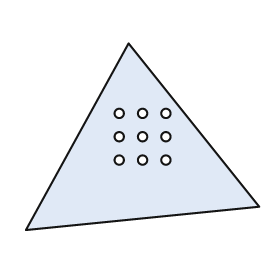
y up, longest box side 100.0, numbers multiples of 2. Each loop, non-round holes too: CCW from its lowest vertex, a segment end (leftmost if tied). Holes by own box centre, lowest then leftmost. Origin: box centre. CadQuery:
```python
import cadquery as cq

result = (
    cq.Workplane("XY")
    .moveTo(-50.0, -40.0)
    .lineTo(50.0, -30.0)
    .lineTo(-6.0, 40.0)
    .close()
    .moveTo(-10.0, -10.0)
    .circle(2.0)
    .moveTo(0.0, -10.0)
    .circle(2.0)
    .moveTo(10.0, -10.0)
    .circle(2.0)
    .moveTo(-10.0, 0.0)
    .circle(2.0)
    .moveTo(0.0, 0.0)
    .circle(2.0)
    .moveTo(10.0, 0.0)
    .circle(2.0)
    .moveTo(-10.0, 10.0)
    .circle(2.0)
    .moveTo(0.0, 10.0)
    .circle(2.0)
    .moveTo(10.0, 10.0)
    .circle(2.0)
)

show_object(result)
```